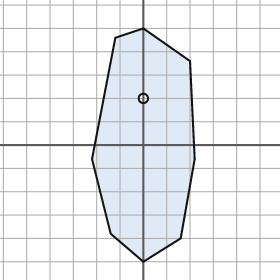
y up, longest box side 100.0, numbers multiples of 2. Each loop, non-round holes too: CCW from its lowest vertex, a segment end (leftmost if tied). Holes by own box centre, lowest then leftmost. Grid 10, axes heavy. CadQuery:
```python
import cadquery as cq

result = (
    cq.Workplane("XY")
    .moveTo(0.0, -50.0)
    .lineTo(16.0, -40.0)
    .lineTo(22.0, -6.0)
    .lineTo(20.0, 36.0)
    .lineTo(0.0, 50.0)
    .lineTo(-12.0, 46.0)
    .lineTo(-22.0, -6.0)
    .lineTo(-14.0, -38.0)
    .close()
    .moveTo(0.0, 20.0)
    .circle(2.0)
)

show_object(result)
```